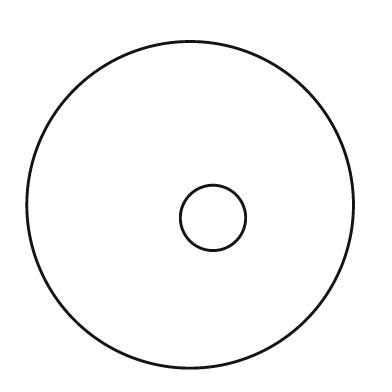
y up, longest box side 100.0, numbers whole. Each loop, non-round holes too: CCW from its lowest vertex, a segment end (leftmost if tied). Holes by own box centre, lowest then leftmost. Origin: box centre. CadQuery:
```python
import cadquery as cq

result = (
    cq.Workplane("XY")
    .moveTo(0.0, 0.0)
    .circle(50.0)
    .moveTo(7.0, -4.0)
    .circle(10.0)
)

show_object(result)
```